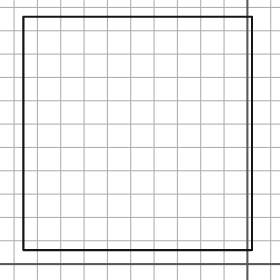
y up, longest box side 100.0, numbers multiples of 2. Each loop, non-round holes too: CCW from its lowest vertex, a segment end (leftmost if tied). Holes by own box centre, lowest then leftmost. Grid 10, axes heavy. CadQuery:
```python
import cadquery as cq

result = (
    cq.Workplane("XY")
    .moveTo(-96.0, 6.0)
    .lineTo(2.0, 6.0)
    .lineTo(2.0, 106.0)
    .lineTo(-96.0, 106.0)
    .close()
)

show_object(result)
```